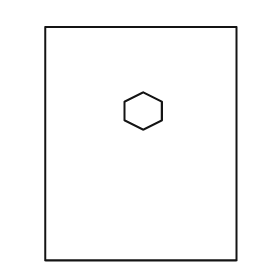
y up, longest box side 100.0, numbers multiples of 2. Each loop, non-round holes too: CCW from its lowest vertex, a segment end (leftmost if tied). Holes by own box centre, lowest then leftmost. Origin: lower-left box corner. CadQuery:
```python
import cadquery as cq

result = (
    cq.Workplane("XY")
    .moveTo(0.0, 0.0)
    .lineTo(82.0, 0.0)
    .lineTo(82.0, 100.0)
    .lineTo(0.0, 100.0)
    .close()
    .moveTo(42.0, 56.0)
    .lineTo(50.0, 60.0)
    .lineTo(50.0, 68.0)
    .lineTo(42.0, 72.0)
    .lineTo(34.0, 68.0)
    .lineTo(34.0, 60.0)
    .close()
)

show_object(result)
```